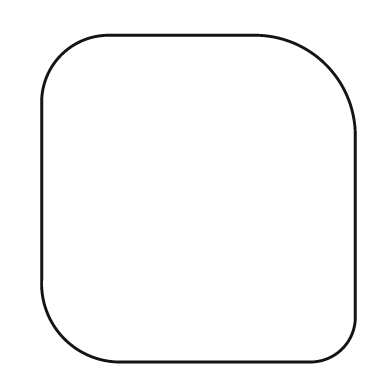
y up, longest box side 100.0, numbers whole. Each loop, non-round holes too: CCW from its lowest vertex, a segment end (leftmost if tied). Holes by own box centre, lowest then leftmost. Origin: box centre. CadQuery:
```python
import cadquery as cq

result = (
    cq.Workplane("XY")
    .moveTo(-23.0, -50.0)
    .lineTo(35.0, -50.0)
    .threePointArc((44.0, -46.0), (48.0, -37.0))
    .lineTo(48.0, 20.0)
    .threePointArc((39.0, 41.0), (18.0, 50.0))
    .lineTo(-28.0, 50.0)
    .threePointArc((-42.0, 44.0), (-48.0, 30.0))
    .lineTo(-48.0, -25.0)
    .threePointArc((-41.0, -43.0), (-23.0, -50.0))
    .close()
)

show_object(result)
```